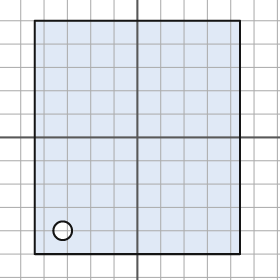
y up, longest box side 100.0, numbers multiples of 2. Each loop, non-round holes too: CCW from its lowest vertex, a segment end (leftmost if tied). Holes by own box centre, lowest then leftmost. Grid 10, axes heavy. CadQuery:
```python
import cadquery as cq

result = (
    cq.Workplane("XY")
    .moveTo(-44.0, -50.0)
    .lineTo(44.0, -50.0)
    .lineTo(44.0, 50.0)
    .lineTo(-44.0, 50.0)
    .close()
    .moveTo(-32.0, -40.0)
    .circle(4.0)
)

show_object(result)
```